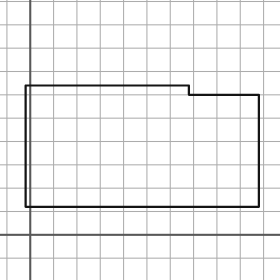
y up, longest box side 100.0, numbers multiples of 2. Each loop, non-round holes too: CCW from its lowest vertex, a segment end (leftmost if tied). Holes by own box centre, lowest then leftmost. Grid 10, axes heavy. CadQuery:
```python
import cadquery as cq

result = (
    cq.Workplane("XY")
    .moveTo(-2.0, 12.0)
    .lineTo(98.0, 12.0)
    .lineTo(98.0, 60.0)
    .lineTo(68.0, 60.0)
    .lineTo(68.0, 64.0)
    .lineTo(-2.0, 64.0)
    .close()
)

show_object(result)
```